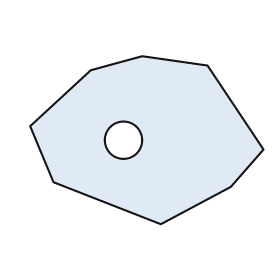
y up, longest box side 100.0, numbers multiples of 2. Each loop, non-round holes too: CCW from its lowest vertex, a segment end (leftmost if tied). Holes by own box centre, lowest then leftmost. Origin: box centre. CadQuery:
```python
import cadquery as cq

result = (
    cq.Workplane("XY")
    .moveTo(6.0, -36.0)
    .lineTo(36.0, -20.0)
    .lineTo(50.0, -4.0)
    .lineTo(26.0, 32.0)
    .lineTo(-2.0, 36.0)
    .lineTo(-24.0, 30.0)
    .lineTo(-50.0, 6.0)
    .lineTo(-40.0, -18.0)
    .close()
    .moveTo(-10.0, 0.0)
    .circle(8.0)
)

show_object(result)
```